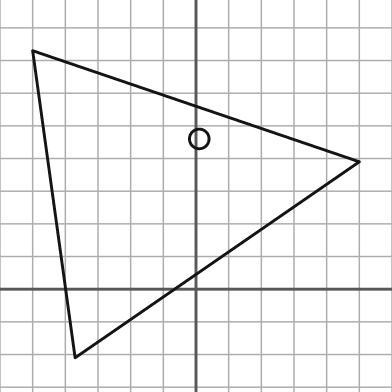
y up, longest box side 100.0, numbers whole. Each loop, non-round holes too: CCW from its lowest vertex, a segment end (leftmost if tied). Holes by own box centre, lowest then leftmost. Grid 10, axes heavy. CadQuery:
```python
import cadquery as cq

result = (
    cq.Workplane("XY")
    .moveTo(-37.0, -21.0)
    .lineTo(50.0, 39.0)
    .lineTo(-50.0, 73.0)
    .close()
    .moveTo(1.0, 46.0)
    .circle(3.0)
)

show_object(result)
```